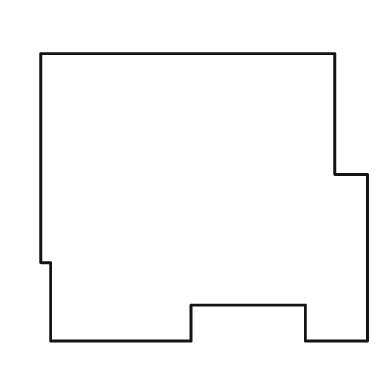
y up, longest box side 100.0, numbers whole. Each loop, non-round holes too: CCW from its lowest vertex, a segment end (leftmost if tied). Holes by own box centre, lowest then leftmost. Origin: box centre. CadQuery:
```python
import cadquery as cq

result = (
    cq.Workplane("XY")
    .moveTo(-47.0, -44.0)
    .lineTo(-4.0, -44.0)
    .lineTo(-4.0, -33.0)
    .lineTo(31.0, -33.0)
    .lineTo(31.0, -44.0)
    .lineTo(50.0, -44.0)
    .lineTo(50.0, 7.0)
    .lineTo(40.0, 7.0)
    .lineTo(40.0, 44.0)
    .lineTo(-50.0, 44.0)
    .lineTo(-50.0, -20.0)
    .lineTo(-47.0, -20.0)
    .close()
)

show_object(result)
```